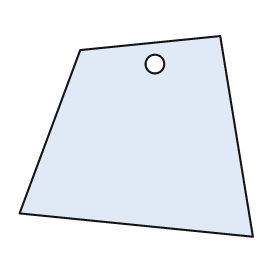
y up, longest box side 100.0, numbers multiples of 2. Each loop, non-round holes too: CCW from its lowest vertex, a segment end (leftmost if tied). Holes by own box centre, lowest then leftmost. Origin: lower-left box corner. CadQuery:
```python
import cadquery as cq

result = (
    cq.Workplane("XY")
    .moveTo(100.0, 0.0)
    .lineTo(86.0, 86.0)
    .lineTo(26.0, 80.0)
    .lineTo(0.0, 10.0)
    .close()
    .moveTo(58.0, 74.0)
    .circle(4.0)
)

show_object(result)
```